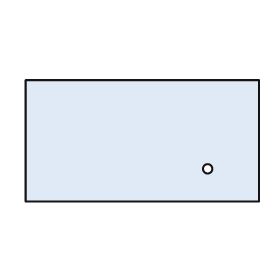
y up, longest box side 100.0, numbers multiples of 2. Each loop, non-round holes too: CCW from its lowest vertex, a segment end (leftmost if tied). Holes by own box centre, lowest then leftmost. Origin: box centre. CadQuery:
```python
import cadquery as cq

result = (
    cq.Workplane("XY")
    .moveTo(-50.0, -26.0)
    .lineTo(50.0, -26.0)
    .lineTo(50.0, 26.0)
    .lineTo(-50.0, 26.0)
    .close()
    .moveTo(28.0, -12.0)
    .circle(2.0)
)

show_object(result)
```